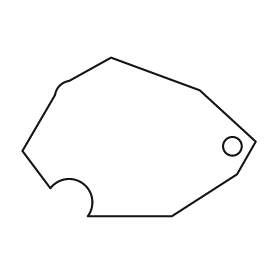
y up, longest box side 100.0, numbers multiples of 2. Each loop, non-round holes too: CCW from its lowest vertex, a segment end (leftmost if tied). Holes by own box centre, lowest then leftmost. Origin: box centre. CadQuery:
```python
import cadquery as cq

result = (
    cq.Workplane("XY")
    .moveTo(-22.0, -34.0)
    .lineTo(14.0, -34.0)
    .lineTo(42.0, -16.0)
    .lineTo(50.0, -2.0)
    .lineTo(26.0, 20.0)
    .lineTo(-12.0, 34.0)
    .lineTo(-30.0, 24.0)
    .threePointArc((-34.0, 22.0), (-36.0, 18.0))
    .lineTo(-50.0, -6.0)
    .lineTo(-38.0, -22.0)
    .threePointArc((-24.0, -20.0), (-22.0, -34.0))
    .close()
    .moveTo(40.0, -4.0)
    .circle(4.0)
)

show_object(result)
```